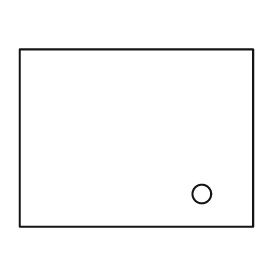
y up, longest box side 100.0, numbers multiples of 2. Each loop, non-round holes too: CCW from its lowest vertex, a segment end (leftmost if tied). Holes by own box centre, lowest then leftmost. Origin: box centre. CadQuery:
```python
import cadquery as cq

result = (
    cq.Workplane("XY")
    .moveTo(-50.0, -38.0)
    .lineTo(50.0, -38.0)
    .lineTo(50.0, 38.0)
    .lineTo(-50.0, 38.0)
    .close()
    .moveTo(28.0, -24.0)
    .circle(4.0)
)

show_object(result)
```